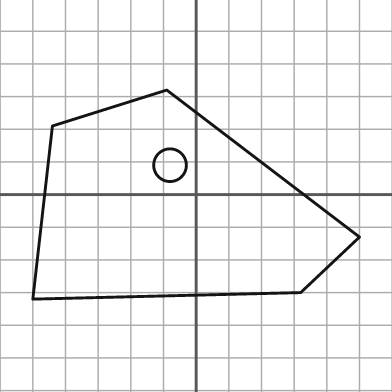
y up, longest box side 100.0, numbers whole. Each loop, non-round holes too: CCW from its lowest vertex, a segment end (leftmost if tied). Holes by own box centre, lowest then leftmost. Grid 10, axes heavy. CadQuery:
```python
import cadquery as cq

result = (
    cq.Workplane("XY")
    .moveTo(-50.0, -32.0)
    .lineTo(32.0, -30.0)
    .lineTo(50.0, -13.0)
    .lineTo(-9.0, 32.0)
    .lineTo(-44.0, 21.0)
    .close()
    .moveTo(-8.0, 9.0)
    .circle(5.0)
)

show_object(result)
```